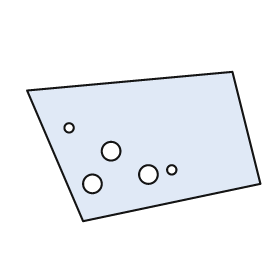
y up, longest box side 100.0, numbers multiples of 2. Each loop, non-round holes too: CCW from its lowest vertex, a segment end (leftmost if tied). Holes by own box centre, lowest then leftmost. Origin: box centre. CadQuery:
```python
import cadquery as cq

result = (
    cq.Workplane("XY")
    .moveTo(-26.0, -32.0)
    .lineTo(50.0, -16.0)
    .lineTo(38.0, 32.0)
    .lineTo(-50.0, 24.0)
    .close()
    .moveTo(-22.0, -16.0)
    .circle(4.0)
    .moveTo(2.0, -12.0)
    .circle(4.0)
    .moveTo(12.0, -10.0)
    .circle(2.0)
    .moveTo(-14.0, -2.0)
    .circle(4.0)
    .moveTo(-32.0, 8.0)
    .circle(2.0)
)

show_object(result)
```